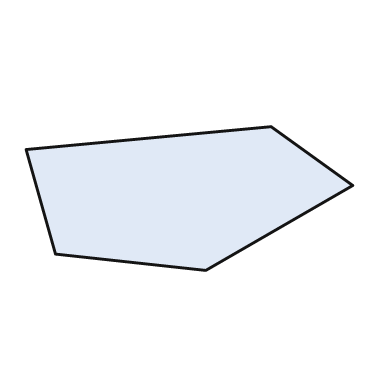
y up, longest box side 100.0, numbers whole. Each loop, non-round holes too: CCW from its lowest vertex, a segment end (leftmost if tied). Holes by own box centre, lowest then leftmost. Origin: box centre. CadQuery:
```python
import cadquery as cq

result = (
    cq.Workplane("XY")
    .moveTo(5.0, -22.0)
    .lineTo(50.0, 4.0)
    .lineTo(25.0, 22.0)
    .lineTo(-50.0, 15.0)
    .lineTo(-41.0, -17.0)
    .close()
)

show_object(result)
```